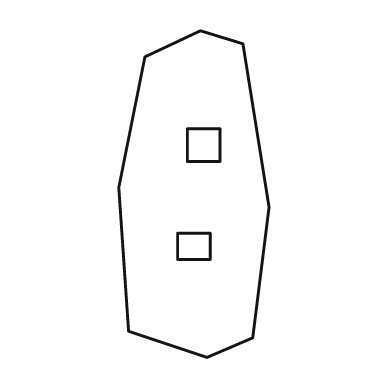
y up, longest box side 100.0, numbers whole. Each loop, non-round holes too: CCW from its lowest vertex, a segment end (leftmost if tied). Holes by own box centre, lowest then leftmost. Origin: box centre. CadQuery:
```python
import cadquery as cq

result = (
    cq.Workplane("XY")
    .moveTo(4.0, -50.0)
    .lineTo(18.0, -44.0)
    .lineTo(23.0, -4.0)
    .lineTo(15.0, 46.0)
    .lineTo(2.0, 50.0)
    .lineTo(-15.0, 42.0)
    .lineTo(-23.0, 2.0)
    .lineTo(-20.0, -42.0)
    .close()
    .moveTo(-5.0, -20.0)
    .lineTo(5.0, -20.0)
    .lineTo(5.0, -12.0)
    .lineTo(-5.0, -12.0)
    .close()
    .moveTo(-2.0, 10.0)
    .lineTo(8.0, 10.0)
    .lineTo(8.0, 20.0)
    .lineTo(-2.0, 20.0)
    .close()
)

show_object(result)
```